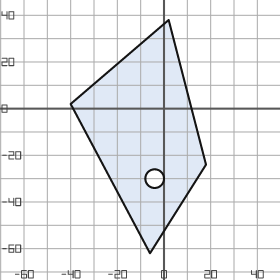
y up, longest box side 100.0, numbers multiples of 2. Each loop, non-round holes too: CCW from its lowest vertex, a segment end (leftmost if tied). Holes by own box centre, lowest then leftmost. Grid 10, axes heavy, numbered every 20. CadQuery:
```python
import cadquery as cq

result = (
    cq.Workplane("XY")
    .moveTo(-6.0, -62.0)
    .lineTo(18.0, -24.0)
    .lineTo(2.0, 38.0)
    .lineTo(-40.0, 2.0)
    .close()
    .moveTo(-4.0, -30.0)
    .circle(4.0)
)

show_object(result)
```